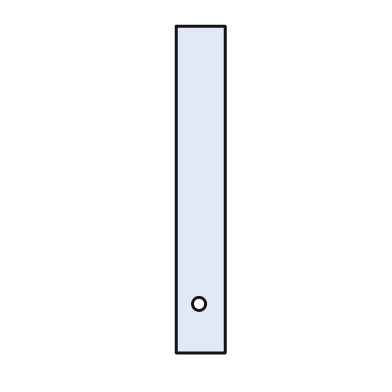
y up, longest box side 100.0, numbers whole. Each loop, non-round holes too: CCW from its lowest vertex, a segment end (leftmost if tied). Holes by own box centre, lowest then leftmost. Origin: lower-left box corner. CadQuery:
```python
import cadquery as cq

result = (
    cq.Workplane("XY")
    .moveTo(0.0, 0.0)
    .lineTo(15.0, 0.0)
    .lineTo(15.0, 100.0)
    .lineTo(0.0, 100.0)
    .close()
    .moveTo(7.0, 15.0)
    .circle(2.0)
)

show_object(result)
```